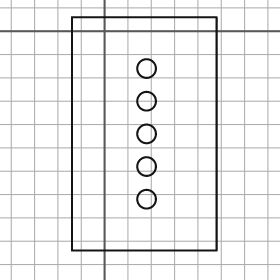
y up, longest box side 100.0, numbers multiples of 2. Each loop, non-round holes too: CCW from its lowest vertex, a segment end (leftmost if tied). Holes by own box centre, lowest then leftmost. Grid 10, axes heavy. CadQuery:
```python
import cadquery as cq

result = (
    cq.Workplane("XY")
    .moveTo(-14.0, -94.0)
    .lineTo(48.0, -94.0)
    .lineTo(48.0, 6.0)
    .lineTo(-14.0, 6.0)
    .close()
    .moveTo(18.0, -72.0)
    .circle(4.0)
    .moveTo(18.0, -58.0)
    .circle(4.0)
    .moveTo(18.0, -44.0)
    .circle(4.0)
    .moveTo(18.0, -30.0)
    .circle(4.0)
    .moveTo(18.0, -16.0)
    .circle(4.0)
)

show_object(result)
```